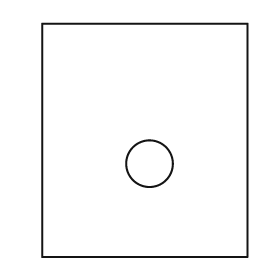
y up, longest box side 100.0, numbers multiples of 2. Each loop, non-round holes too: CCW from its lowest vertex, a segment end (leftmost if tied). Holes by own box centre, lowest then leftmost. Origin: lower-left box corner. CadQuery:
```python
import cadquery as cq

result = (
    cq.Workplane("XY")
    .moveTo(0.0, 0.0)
    .lineTo(88.0, 0.0)
    .lineTo(88.0, 100.0)
    .lineTo(0.0, 100.0)
    .close()
    .moveTo(46.0, 40.0)
    .circle(10.0)
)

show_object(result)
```